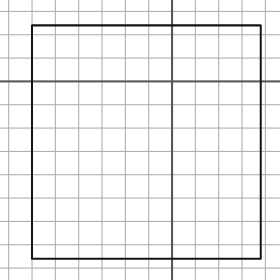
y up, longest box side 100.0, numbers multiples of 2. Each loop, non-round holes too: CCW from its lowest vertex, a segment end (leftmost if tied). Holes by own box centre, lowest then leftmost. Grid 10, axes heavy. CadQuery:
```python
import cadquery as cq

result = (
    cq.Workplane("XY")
    .moveTo(-60.0, -76.0)
    .lineTo(38.0, -76.0)
    .lineTo(38.0, 24.0)
    .lineTo(-60.0, 24.0)
    .close()
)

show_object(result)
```